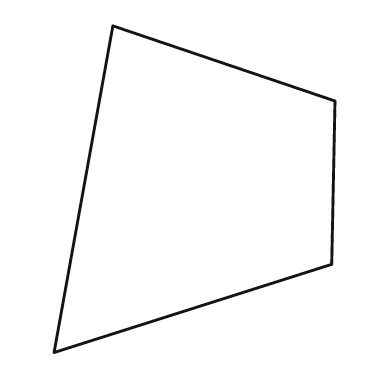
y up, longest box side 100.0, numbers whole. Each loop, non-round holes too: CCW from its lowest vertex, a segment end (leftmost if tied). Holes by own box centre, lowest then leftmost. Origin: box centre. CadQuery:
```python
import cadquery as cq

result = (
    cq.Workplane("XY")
    .moveTo(-43.0, -50.0)
    .lineTo(42.0, -23.0)
    .lineTo(43.0, 27.0)
    .lineTo(-25.0, 50.0)
    .close()
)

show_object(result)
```